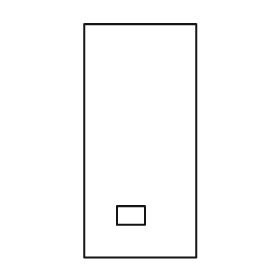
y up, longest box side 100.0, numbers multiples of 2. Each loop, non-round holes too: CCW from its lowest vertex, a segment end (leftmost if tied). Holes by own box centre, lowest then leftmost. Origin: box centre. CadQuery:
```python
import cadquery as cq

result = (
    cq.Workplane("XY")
    .moveTo(-24.0, -50.0)
    .lineTo(24.0, -50.0)
    .lineTo(24.0, 50.0)
    .lineTo(-24.0, 50.0)
    .close()
    .moveTo(-10.0, -36.0)
    .lineTo(2.0, -36.0)
    .lineTo(2.0, -28.0)
    .lineTo(-10.0, -28.0)
    .close()
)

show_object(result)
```